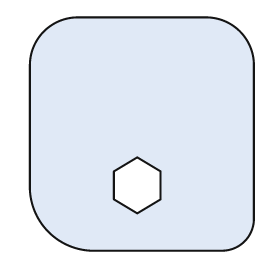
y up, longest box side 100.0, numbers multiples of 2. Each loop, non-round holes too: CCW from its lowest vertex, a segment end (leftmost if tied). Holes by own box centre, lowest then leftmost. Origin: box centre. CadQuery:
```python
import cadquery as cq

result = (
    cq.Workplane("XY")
    .moveTo(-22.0, -50.0)
    .lineTo(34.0, -50.0)
    .threePointArc((44.0, -46.0), (48.0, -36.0))
    .lineTo(48.0, 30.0)
    .threePointArc((42.0, 44.0), (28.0, 50.0))
    .lineTo(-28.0, 50.0)
    .threePointArc((-42.0, 44.0), (-48.0, 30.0))
    .lineTo(-48.0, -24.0)
    .threePointArc((-40.0, -42.0), (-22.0, -50.0))
    .close()
    .moveTo(-2.0, -34.0)
    .lineTo(8.0, -28.0)
    .lineTo(8.0, -16.0)
    .lineTo(-2.0, -10.0)
    .lineTo(-12.0, -16.0)
    .lineTo(-12.0, -28.0)
    .close()
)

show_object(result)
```